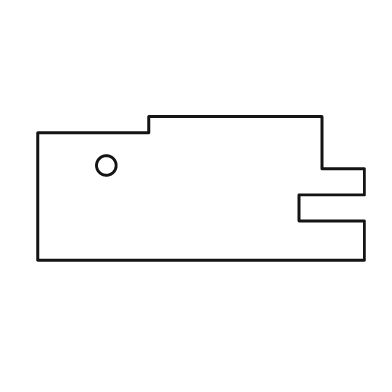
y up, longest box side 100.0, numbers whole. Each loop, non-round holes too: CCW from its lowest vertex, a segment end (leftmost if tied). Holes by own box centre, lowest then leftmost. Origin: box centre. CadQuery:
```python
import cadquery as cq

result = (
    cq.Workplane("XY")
    .moveTo(-50.0, -22.0)
    .lineTo(50.0, -22.0)
    .lineTo(50.0, -10.0)
    .lineTo(30.0, -10.0)
    .lineTo(30.0, -2.0)
    .lineTo(50.0, -2.0)
    .lineTo(50.0, 6.0)
    .lineTo(37.0, 6.0)
    .lineTo(37.0, 22.0)
    .lineTo(-16.0, 22.0)
    .lineTo(-16.0, 17.0)
    .lineTo(-50.0, 17.0)
    .close()
    .moveTo(-29.0, 7.0)
    .circle(3.0)
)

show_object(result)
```